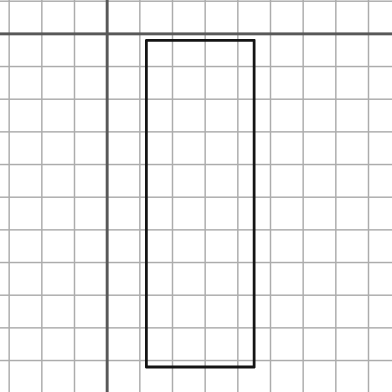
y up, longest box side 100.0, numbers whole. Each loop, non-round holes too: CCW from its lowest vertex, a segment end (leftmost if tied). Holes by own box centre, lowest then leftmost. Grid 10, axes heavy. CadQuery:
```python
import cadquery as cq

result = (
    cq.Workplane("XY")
    .moveTo(12.0, -102.0)
    .lineTo(45.0, -102.0)
    .lineTo(45.0, -2.0)
    .lineTo(12.0, -2.0)
    .close()
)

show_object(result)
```